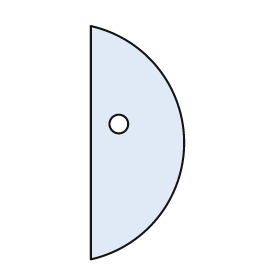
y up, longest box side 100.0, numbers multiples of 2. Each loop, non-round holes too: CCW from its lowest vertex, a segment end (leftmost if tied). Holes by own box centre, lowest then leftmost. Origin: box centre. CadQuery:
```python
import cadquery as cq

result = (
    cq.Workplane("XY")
    .moveTo(-20.0, -50.0)
    .threePointArc((20.0, 0.0), (-20.0, 50.0))
    .close()
    .moveTo(-8.0, 8.0)
    .circle(4.0)
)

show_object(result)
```